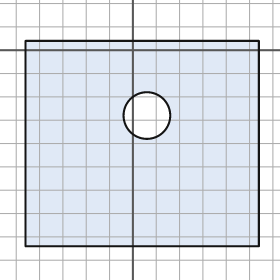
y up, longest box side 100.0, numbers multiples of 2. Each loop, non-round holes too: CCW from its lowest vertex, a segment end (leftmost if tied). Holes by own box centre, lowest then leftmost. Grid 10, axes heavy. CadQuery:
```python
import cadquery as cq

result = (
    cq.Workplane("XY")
    .moveTo(-46.0, -84.0)
    .lineTo(54.0, -84.0)
    .lineTo(54.0, 4.0)
    .lineTo(-46.0, 4.0)
    .close()
    .moveTo(6.0, -28.0)
    .circle(10.0)
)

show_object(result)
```